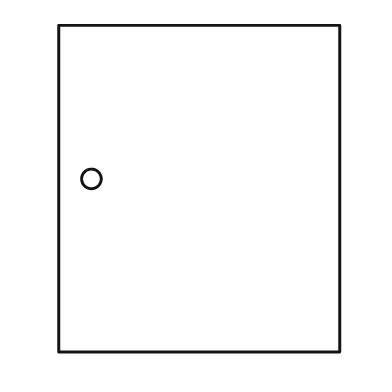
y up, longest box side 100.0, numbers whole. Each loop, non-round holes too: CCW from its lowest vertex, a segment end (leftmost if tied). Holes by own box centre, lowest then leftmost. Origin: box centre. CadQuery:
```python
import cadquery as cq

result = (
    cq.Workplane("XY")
    .moveTo(-43.0, -50.0)
    .lineTo(43.0, -50.0)
    .lineTo(43.0, 50.0)
    .lineTo(-43.0, 50.0)
    .close()
    .moveTo(-33.0, 3.0)
    .circle(3.0)
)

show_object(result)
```